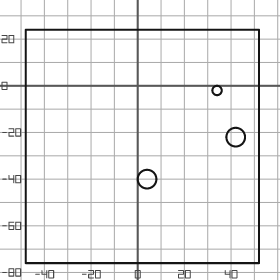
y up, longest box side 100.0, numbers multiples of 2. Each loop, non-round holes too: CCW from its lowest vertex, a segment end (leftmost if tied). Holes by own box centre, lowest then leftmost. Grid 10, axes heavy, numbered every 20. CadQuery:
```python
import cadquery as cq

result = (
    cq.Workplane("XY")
    .moveTo(-48.0, -76.0)
    .lineTo(52.0, -76.0)
    .lineTo(52.0, 24.0)
    .lineTo(-48.0, 24.0)
    .close()
    .moveTo(4.0, -40.0)
    .circle(4.0)
    .moveTo(42.0, -22.0)
    .circle(4.0)
    .moveTo(34.0, -2.0)
    .circle(2.0)
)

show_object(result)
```